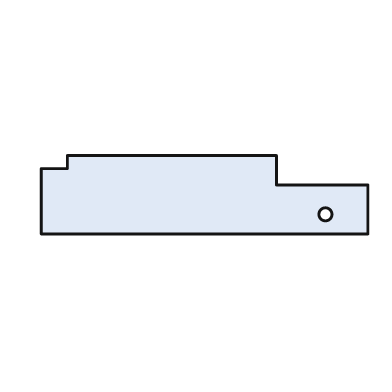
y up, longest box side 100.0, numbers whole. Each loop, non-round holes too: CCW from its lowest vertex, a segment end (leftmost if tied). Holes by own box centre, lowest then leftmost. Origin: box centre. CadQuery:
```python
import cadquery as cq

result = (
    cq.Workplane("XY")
    .moveTo(-50.0, -12.0)
    .lineTo(50.0, -12.0)
    .lineTo(50.0, 3.0)
    .lineTo(22.0, 3.0)
    .lineTo(22.0, 12.0)
    .lineTo(-42.0, 12.0)
    .lineTo(-42.0, 8.0)
    .lineTo(-50.0, 8.0)
    .close()
    .moveTo(37.0, -6.0)
    .circle(2.0)
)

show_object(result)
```